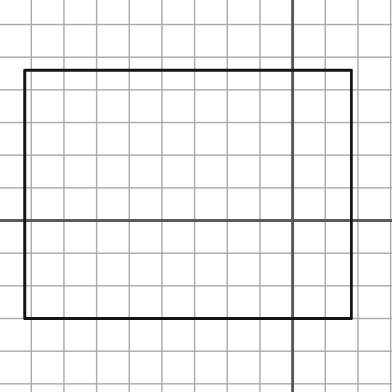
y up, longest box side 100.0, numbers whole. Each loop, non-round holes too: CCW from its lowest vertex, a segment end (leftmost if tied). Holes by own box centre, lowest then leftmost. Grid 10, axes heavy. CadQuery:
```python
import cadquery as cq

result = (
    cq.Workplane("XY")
    .moveTo(-82.0, -30.0)
    .lineTo(18.0, -30.0)
    .lineTo(18.0, 46.0)
    .lineTo(-82.0, 46.0)
    .close()
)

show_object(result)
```